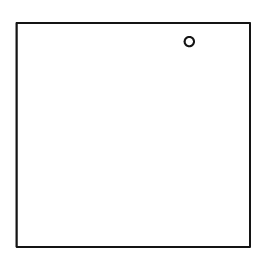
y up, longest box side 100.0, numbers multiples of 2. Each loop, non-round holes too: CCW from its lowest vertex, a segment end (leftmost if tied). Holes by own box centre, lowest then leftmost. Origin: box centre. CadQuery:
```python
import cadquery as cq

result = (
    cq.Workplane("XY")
    .moveTo(-50.0, -48.0)
    .lineTo(50.0, -48.0)
    .lineTo(50.0, 48.0)
    .lineTo(-50.0, 48.0)
    .close()
    .moveTo(24.0, 40.0)
    .circle(2.0)
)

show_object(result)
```